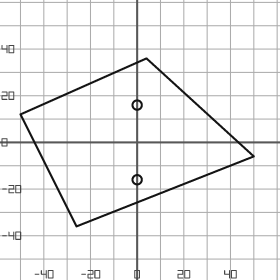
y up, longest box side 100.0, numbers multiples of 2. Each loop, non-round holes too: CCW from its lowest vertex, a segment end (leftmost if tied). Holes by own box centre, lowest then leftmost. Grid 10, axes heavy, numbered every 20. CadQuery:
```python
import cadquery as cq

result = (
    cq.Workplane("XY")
    .moveTo(-26.0, -36.0)
    .lineTo(50.0, -6.0)
    .lineTo(4.0, 36.0)
    .lineTo(-50.0, 12.0)
    .close()
    .moveTo(0.0, -16.0)
    .circle(2.0)
    .moveTo(0.0, 16.0)
    .circle(2.0)
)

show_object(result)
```